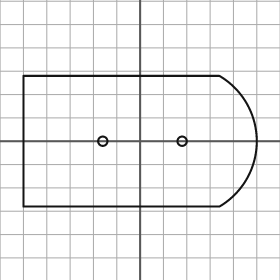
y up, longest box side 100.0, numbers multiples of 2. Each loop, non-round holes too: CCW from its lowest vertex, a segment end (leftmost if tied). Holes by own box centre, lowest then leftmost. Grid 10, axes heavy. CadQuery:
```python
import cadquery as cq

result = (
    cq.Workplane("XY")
    .moveTo(-50.0, -28.0)
    .lineTo(34.0, -28.0)
    .threePointArc((50.0, 0.0), (34.0, 28.0))
    .lineTo(-50.0, 28.0)
    .close()
    .moveTo(-16.0, 0.0)
    .circle(2.0)
    .moveTo(18.0, 0.0)
    .circle(2.0)
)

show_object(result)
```